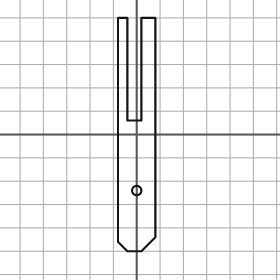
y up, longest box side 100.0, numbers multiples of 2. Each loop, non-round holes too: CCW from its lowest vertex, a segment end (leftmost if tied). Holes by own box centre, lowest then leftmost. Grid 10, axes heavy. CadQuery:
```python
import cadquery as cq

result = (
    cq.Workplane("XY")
    .moveTo(-4.0, -50.0)
    .lineTo(2.0, -50.0)
    .lineTo(8.0, -44.0)
    .lineTo(8.0, 50.0)
    .lineTo(2.0, 50.0)
    .lineTo(2.0, 6.0)
    .lineTo(-4.0, 6.0)
    .lineTo(-4.0, 50.0)
    .lineTo(-8.0, 50.0)
    .lineTo(-8.0, -46.0)
    .close()
    .moveTo(0.0, -24.0)
    .circle(2.0)
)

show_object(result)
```